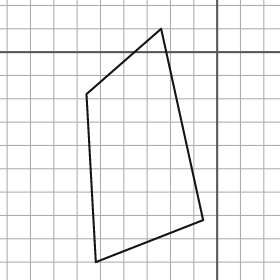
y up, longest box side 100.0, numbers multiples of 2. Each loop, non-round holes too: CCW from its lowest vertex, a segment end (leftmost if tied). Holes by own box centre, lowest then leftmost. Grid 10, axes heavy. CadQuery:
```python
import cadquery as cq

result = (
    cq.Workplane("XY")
    .moveTo(-52.0, -90.0)
    .lineTo(-6.0, -72.0)
    .lineTo(-24.0, 10.0)
    .lineTo(-56.0, -18.0)
    .close()
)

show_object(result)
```